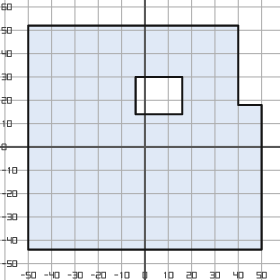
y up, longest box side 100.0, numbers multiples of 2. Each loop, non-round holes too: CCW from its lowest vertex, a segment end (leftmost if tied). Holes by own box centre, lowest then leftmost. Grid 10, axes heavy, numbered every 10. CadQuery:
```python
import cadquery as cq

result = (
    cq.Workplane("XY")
    .moveTo(-50.0, -44.0)
    .lineTo(50.0, -44.0)
    .lineTo(50.0, 18.0)
    .lineTo(40.0, 18.0)
    .lineTo(40.0, 52.0)
    .lineTo(-50.0, 52.0)
    .close()
    .moveTo(-4.0, 14.0)
    .lineTo(16.0, 14.0)
    .lineTo(16.0, 30.0)
    .lineTo(-4.0, 30.0)
    .close()
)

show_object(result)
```